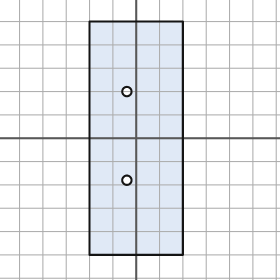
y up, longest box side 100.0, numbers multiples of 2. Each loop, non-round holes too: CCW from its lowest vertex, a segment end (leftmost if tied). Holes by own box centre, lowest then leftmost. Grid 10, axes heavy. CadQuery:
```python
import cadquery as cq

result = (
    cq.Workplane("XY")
    .moveTo(-20.0, -50.0)
    .lineTo(20.0, -50.0)
    .lineTo(20.0, 50.0)
    .lineTo(-20.0, 50.0)
    .close()
    .moveTo(-4.0, -18.0)
    .circle(2.0)
    .moveTo(-4.0, 20.0)
    .circle(2.0)
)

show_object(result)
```